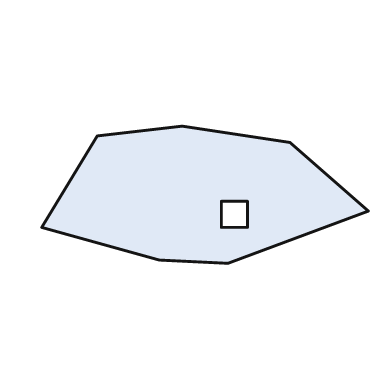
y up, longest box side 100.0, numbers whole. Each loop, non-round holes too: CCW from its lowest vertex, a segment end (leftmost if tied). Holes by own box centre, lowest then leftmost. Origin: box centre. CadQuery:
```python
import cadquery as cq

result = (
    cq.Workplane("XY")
    .moveTo(7.0, -21.0)
    .lineTo(50.0, -5.0)
    .lineTo(26.0, 16.0)
    .lineTo(-7.0, 21.0)
    .lineTo(-33.0, 18.0)
    .lineTo(-50.0, -10.0)
    .lineTo(-14.0, -20.0)
    .close()
    .moveTo(5.0, -10.0)
    .lineTo(13.0, -10.0)
    .lineTo(13.0, -2.0)
    .lineTo(5.0, -2.0)
    .close()
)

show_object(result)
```